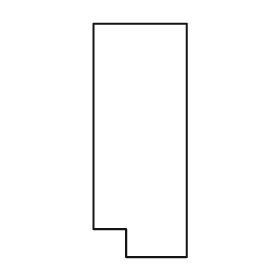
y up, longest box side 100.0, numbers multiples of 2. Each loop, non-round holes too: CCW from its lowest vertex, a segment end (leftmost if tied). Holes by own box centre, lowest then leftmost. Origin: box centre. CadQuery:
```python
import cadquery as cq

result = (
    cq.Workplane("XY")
    .moveTo(-6.0, -50.0)
    .lineTo(20.0, -50.0)
    .lineTo(20.0, 50.0)
    .lineTo(-20.0, 50.0)
    .lineTo(-20.0, -38.0)
    .lineTo(-6.0, -38.0)
    .close()
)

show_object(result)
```